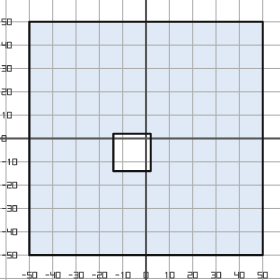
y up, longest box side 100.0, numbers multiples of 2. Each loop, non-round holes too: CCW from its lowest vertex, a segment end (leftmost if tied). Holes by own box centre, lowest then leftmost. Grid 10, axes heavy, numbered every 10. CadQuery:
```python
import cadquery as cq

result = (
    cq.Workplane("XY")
    .moveTo(-50.0, -50.0)
    .lineTo(50.0, -50.0)
    .lineTo(50.0, 50.0)
    .lineTo(-50.0, 50.0)
    .close()
    .moveTo(-14.0, -14.0)
    .lineTo(2.0, -14.0)
    .lineTo(2.0, 2.0)
    .lineTo(-14.0, 2.0)
    .close()
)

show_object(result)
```